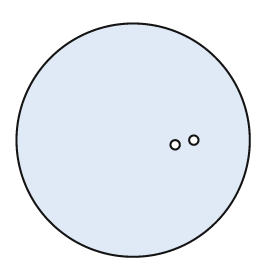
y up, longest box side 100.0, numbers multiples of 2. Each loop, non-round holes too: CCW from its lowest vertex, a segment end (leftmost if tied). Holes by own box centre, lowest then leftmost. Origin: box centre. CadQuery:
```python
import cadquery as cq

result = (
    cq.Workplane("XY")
    .moveTo(0.0, 0.0)
    .circle(50.0)
    .moveTo(18.0, -2.0)
    .circle(2.0)
    .moveTo(26.0, 0.0)
    .circle(2.0)
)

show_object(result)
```